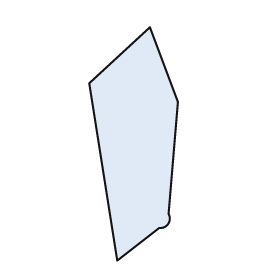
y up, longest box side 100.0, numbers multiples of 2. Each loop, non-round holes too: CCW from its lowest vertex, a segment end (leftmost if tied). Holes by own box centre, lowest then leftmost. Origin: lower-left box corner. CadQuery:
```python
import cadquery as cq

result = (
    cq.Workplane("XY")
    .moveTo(12.0, 0.0)
    .lineTo(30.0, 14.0)
    .threePointArc((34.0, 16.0), (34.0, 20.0))
    .lineTo(38.0, 68.0)
    .lineTo(26.0, 100.0)
    .lineTo(0.0, 76.0)
    .close()
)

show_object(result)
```